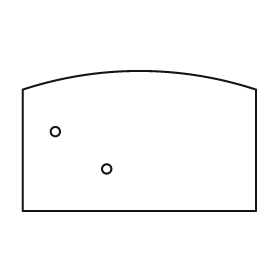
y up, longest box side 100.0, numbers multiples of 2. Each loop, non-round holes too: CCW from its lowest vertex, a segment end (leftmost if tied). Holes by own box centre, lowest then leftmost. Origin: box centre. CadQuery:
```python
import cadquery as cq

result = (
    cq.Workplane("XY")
    .moveTo(-50.0, -30.0)
    .lineTo(50.0, -30.0)
    .lineTo(50.0, 22.0)
    .threePointArc((0.0, 30.0), (-50.0, 22.0))
    .close()
    .moveTo(-14.0, -12.0)
    .circle(2.0)
    .moveTo(-36.0, 4.0)
    .circle(2.0)
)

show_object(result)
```